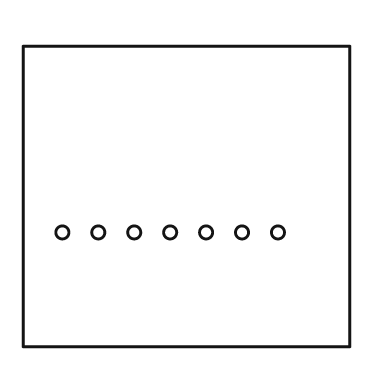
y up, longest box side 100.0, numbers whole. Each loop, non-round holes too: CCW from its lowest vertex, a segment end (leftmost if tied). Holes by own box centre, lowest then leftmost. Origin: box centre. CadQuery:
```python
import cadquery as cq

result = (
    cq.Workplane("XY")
    .moveTo(-50.0, -46.0)
    .lineTo(50.0, -46.0)
    .lineTo(50.0, 46.0)
    .lineTo(-50.0, 46.0)
    .close()
    .moveTo(-38.0, -11.0)
    .circle(2.0)
    .moveTo(-27.0, -11.0)
    .circle(2.0)
    .moveTo(-16.0, -11.0)
    .circle(2.0)
    .moveTo(-5.0, -11.0)
    .circle(2.0)
    .moveTo(6.0, -11.0)
    .circle(2.0)
    .moveTo(17.0, -11.0)
    .circle(2.0)
    .moveTo(28.0, -11.0)
    .circle(2.0)
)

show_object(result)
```